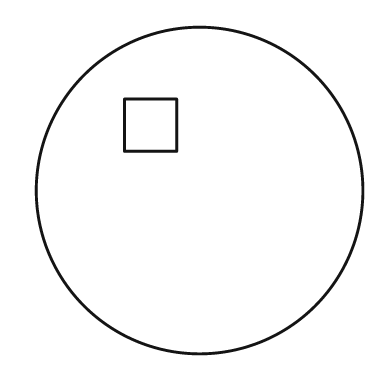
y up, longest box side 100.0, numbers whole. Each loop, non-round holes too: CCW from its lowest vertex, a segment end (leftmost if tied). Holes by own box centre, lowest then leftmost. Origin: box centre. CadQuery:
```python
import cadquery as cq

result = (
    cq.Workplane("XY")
    .moveTo(0.0, 0.0)
    .circle(50.0)
    .moveTo(-23.0, 12.0)
    .lineTo(-7.0, 12.0)
    .lineTo(-7.0, 28.0)
    .lineTo(-23.0, 28.0)
    .close()
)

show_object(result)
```